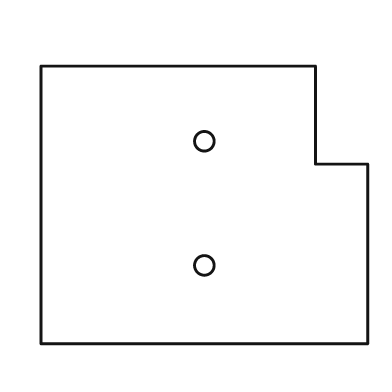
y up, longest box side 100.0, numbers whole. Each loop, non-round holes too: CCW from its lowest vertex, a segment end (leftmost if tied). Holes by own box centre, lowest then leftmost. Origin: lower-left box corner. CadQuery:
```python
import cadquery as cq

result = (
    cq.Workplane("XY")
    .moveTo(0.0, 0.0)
    .lineTo(100.0, 0.0)
    .lineTo(100.0, 55.0)
    .lineTo(84.0, 55.0)
    .lineTo(84.0, 85.0)
    .lineTo(0.0, 85.0)
    .close()
    .moveTo(50.0, 24.0)
    .circle(3.0)
    .moveTo(50.0, 62.0)
    .circle(3.0)
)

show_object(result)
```